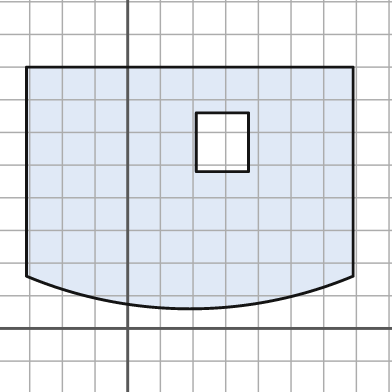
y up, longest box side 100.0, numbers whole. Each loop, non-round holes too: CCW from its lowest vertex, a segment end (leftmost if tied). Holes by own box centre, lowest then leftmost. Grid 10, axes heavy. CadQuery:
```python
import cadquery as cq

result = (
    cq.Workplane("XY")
    .moveTo(-31.0, 16.0)
    .threePointArc((19.0, 6.0), (69.0, 16.0))
    .lineTo(69.0, 80.0)
    .lineTo(-31.0, 80.0)
    .close()
    .moveTo(21.0, 48.0)
    .lineTo(37.0, 48.0)
    .lineTo(37.0, 66.0)
    .lineTo(21.0, 66.0)
    .close()
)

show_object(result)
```